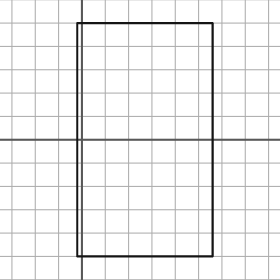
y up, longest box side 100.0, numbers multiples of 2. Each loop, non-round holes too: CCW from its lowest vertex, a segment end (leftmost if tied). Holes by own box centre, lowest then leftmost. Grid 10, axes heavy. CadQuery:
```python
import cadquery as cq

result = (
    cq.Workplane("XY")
    .moveTo(-2.0, -50.0)
    .lineTo(56.0, -50.0)
    .lineTo(56.0, 50.0)
    .lineTo(-2.0, 50.0)
    .close()
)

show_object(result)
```